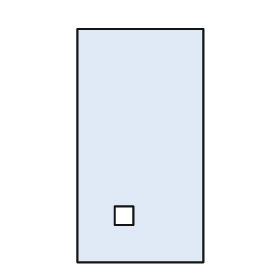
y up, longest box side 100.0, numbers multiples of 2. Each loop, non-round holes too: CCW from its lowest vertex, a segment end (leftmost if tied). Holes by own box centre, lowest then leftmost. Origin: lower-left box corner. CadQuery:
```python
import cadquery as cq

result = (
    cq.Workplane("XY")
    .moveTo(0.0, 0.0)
    .lineTo(54.0, 0.0)
    .lineTo(54.0, 100.0)
    .lineTo(0.0, 100.0)
    .close()
    .moveTo(16.0, 16.0)
    .lineTo(24.0, 16.0)
    .lineTo(24.0, 24.0)
    .lineTo(16.0, 24.0)
    .close()
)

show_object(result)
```